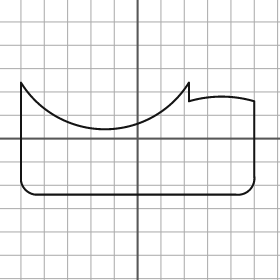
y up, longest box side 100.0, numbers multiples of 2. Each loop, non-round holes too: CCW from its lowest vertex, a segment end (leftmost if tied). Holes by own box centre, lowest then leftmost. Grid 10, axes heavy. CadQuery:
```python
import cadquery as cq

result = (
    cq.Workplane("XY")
    .moveTo(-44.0, -24.0)
    .lineTo(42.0, -24.0)
    .threePointArc((48.0, -22.0), (50.0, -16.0))
    .lineTo(50.0, 16.0)
    .threePointArc((36.0, 18.0), (22.0, 16.0))
    .lineTo(22.0, 24.0)
    .threePointArc((-14.0, 4.0), (-50.0, 24.0))
    .lineTo(-50.0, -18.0)
    .threePointArc((-48.0, -22.0), (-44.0, -24.0))
    .close()
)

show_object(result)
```